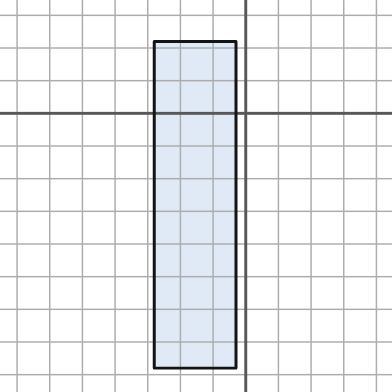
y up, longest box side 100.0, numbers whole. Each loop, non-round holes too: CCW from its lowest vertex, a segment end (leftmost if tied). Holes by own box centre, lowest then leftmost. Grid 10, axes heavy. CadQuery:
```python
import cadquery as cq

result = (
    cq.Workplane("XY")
    .moveTo(-28.0, -78.0)
    .lineTo(-3.0, -78.0)
    .lineTo(-3.0, 22.0)
    .lineTo(-28.0, 22.0)
    .close()
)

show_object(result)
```